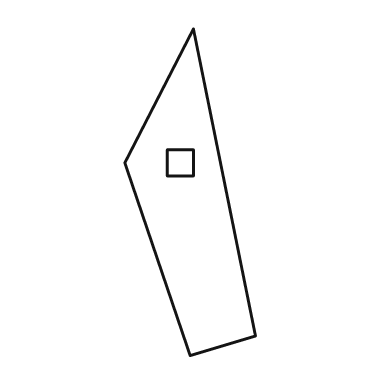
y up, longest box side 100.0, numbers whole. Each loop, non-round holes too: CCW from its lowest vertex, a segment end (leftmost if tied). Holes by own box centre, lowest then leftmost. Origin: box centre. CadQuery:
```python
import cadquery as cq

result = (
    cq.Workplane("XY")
    .moveTo(0.0, -50.0)
    .lineTo(20.0, -44.0)
    .lineTo(1.0, 50.0)
    .lineTo(-20.0, 9.0)
    .close()
    .moveTo(-7.0, 5.0)
    .lineTo(1.0, 5.0)
    .lineTo(1.0, 13.0)
    .lineTo(-7.0, 13.0)
    .close()
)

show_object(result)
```